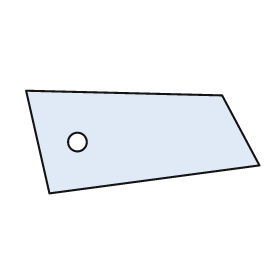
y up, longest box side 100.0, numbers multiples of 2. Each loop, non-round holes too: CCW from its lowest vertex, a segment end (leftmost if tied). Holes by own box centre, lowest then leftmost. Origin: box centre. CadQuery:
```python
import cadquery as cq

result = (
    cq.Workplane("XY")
    .moveTo(-40.0, -22.0)
    .lineTo(50.0, -10.0)
    .lineTo(34.0, 20.0)
    .lineTo(-50.0, 22.0)
    .close()
    .moveTo(-28.0, 0.0)
    .circle(4.0)
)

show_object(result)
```